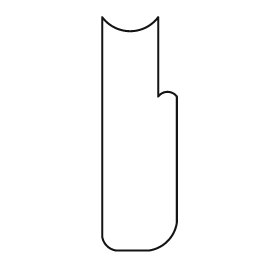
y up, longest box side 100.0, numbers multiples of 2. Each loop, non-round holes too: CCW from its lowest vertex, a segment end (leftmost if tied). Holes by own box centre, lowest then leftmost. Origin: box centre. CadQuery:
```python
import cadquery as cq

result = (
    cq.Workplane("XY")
    .moveTo(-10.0, -50.0)
    .lineTo(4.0, -50.0)
    .threePointArc((12.0, -46.0), (16.0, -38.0))
    .lineTo(16.0, 16.0)
    .threePointArc((12.0, 18.0), (8.0, 16.0))
    .lineTo(8.0, 50.0)
    .threePointArc((-4.0, 44.0), (-16.0, 50.0))
    .lineTo(-16.0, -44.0)
    .threePointArc((-14.0, -48.0), (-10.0, -50.0))
    .close()
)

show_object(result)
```